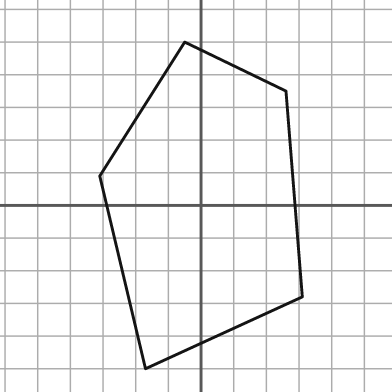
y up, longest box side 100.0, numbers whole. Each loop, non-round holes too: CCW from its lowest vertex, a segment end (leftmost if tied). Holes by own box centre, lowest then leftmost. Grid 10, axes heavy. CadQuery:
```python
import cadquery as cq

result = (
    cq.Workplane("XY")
    .moveTo(-17.0, -50.0)
    .lineTo(31.0, -28.0)
    .lineTo(26.0, 35.0)
    .lineTo(-5.0, 50.0)
    .lineTo(-31.0, 9.0)
    .close()
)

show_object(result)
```